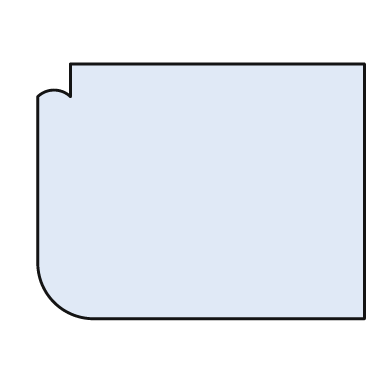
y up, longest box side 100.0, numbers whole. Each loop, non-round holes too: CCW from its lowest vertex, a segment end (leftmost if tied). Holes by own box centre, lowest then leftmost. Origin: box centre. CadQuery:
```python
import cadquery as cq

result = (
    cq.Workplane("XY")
    .moveTo(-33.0, -39.0)
    .lineTo(50.0, -39.0)
    .lineTo(50.0, 39.0)
    .lineTo(-40.0, 39.0)
    .lineTo(-40.0, 29.0)
    .threePointArc((-45.0, 31.0), (-50.0, 29.0))
    .lineTo(-50.0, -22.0)
    .threePointArc((-45.0, -34.0), (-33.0, -39.0))
    .close()
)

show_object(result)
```